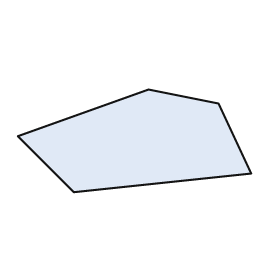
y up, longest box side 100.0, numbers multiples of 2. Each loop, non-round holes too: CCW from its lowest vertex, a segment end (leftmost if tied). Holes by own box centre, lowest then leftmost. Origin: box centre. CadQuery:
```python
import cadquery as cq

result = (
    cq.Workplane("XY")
    .moveTo(-26.0, -22.0)
    .lineTo(50.0, -14.0)
    .lineTo(36.0, 16.0)
    .lineTo(6.0, 22.0)
    .lineTo(-50.0, 2.0)
    .close()
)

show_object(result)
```